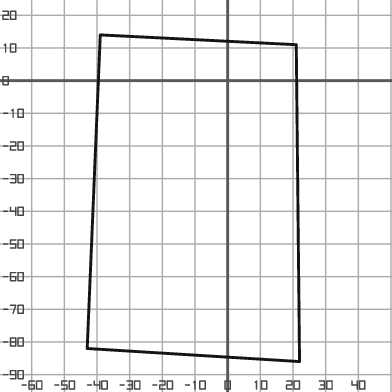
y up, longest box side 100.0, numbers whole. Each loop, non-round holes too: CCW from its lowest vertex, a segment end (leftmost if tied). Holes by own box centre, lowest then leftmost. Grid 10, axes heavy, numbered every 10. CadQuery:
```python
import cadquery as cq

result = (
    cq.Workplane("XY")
    .moveTo(22.0, -86.0)
    .lineTo(21.0, 11.0)
    .lineTo(-39.0, 14.0)
    .lineTo(-43.0, -82.0)
    .close()
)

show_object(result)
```